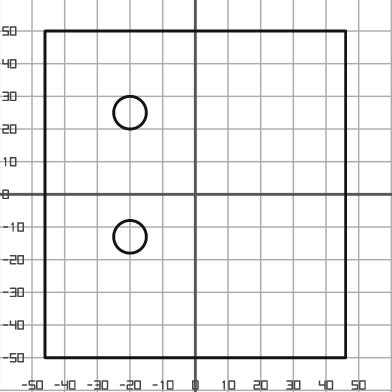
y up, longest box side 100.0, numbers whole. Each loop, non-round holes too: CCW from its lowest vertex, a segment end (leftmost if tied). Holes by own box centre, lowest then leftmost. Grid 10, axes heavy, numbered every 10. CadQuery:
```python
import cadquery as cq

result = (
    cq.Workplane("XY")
    .moveTo(-46.0, -50.0)
    .lineTo(46.0, -50.0)
    .lineTo(46.0, 50.0)
    .lineTo(-46.0, 50.0)
    .close()
    .moveTo(-20.0, -13.0)
    .circle(5.0)
    .moveTo(-20.0, 25.0)
    .circle(5.0)
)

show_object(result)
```